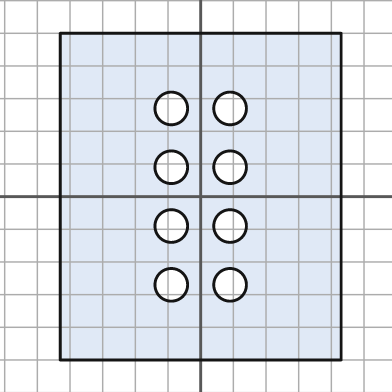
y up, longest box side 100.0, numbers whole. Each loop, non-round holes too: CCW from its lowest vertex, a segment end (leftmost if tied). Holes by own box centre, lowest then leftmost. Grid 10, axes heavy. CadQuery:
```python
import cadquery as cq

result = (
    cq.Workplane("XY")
    .moveTo(-43.0, -50.0)
    .lineTo(43.0, -50.0)
    .lineTo(43.0, 50.0)
    .lineTo(-43.0, 50.0)
    .close()
    .moveTo(-9.0, -27.0)
    .circle(5.0)
    .moveTo(9.0, -27.0)
    .circle(5.0)
    .moveTo(-9.0, -9.0)
    .circle(5.0)
    .moveTo(9.0, -9.0)
    .circle(5.0)
    .moveTo(-9.0, 9.0)
    .circle(5.0)
    .moveTo(9.0, 9.0)
    .circle(5.0)
    .moveTo(-9.0, 27.0)
    .circle(5.0)
    .moveTo(9.0, 27.0)
    .circle(5.0)
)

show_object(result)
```